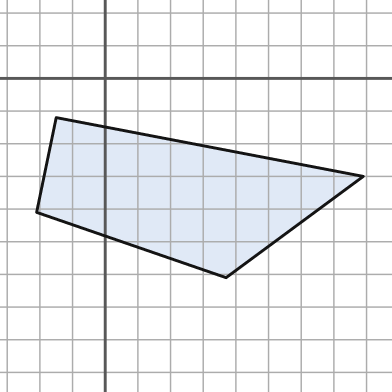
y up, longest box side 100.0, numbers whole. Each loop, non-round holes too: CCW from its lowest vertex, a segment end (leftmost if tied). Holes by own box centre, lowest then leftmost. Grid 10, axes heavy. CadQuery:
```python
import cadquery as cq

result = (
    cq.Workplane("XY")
    .moveTo(37.0, -61.0)
    .lineTo(79.0, -30.0)
    .lineTo(-15.0, -12.0)
    .lineTo(-21.0, -41.0)
    .close()
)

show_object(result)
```